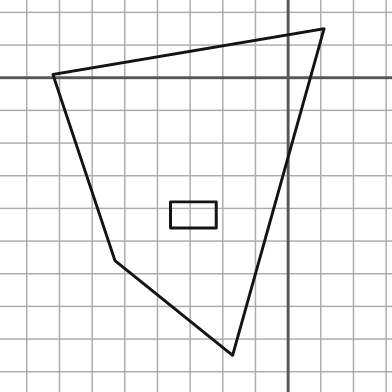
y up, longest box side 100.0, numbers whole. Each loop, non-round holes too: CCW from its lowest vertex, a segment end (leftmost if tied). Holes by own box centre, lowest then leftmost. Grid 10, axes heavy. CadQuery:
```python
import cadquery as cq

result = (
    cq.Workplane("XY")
    .moveTo(-17.0, -85.0)
    .lineTo(11.0, 15.0)
    .lineTo(-72.0, 1.0)
    .lineTo(-53.0, -56.0)
    .close()
    .moveTo(-36.0, -46.0)
    .lineTo(-22.0, -46.0)
    .lineTo(-22.0, -38.0)
    .lineTo(-36.0, -38.0)
    .close()
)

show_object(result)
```